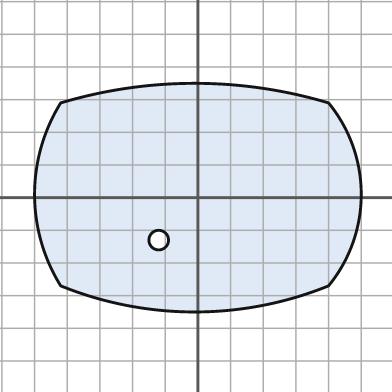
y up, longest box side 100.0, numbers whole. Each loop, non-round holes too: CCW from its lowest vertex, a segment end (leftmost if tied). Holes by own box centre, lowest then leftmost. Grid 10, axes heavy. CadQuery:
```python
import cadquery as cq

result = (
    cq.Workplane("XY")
    .moveTo(-42.0, -27.0)
    .threePointArc((-1.0, -35.0), (40.0, -27.0))
    .threePointArc((50.0, 1.0), (40.0, 29.0))
    .threePointArc((-1.0, 35.0), (-42.0, 29.0))
    .threePointArc((-50.0, 1.0), (-42.0, -27.0))
    .close()
    .moveTo(-12.0, -13.0)
    .circle(3.0)
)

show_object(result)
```